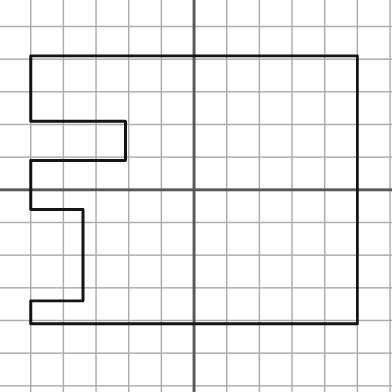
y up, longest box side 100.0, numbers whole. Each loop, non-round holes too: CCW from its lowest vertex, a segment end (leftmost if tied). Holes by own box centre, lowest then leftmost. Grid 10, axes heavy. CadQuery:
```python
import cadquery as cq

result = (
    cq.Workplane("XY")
    .moveTo(-50.0, -41.0)
    .lineTo(50.0, -41.0)
    .lineTo(50.0, 41.0)
    .lineTo(-50.0, 41.0)
    .lineTo(-50.0, 21.0)
    .lineTo(-21.0, 21.0)
    .lineTo(-21.0, 9.0)
    .lineTo(-50.0, 9.0)
    .lineTo(-50.0, -6.0)
    .lineTo(-34.0, -6.0)
    .lineTo(-34.0, -34.0)
    .lineTo(-50.0, -34.0)
    .close()
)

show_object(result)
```